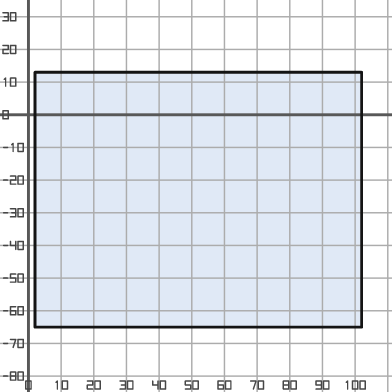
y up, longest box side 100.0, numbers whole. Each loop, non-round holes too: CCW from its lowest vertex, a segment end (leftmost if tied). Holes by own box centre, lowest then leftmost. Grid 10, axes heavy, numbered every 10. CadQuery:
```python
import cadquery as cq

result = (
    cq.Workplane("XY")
    .moveTo(2.0, -65.0)
    .lineTo(102.0, -65.0)
    .lineTo(102.0, 13.0)
    .lineTo(2.0, 13.0)
    .close()
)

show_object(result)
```